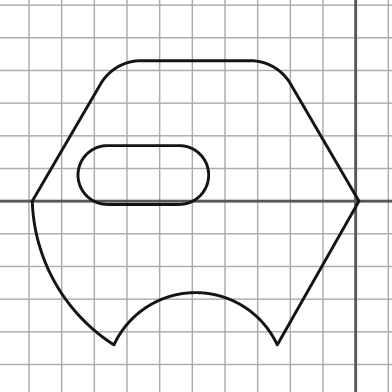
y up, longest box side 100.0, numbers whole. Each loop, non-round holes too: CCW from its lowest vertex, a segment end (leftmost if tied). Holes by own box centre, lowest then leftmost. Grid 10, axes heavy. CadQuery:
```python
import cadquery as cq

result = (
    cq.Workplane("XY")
    .moveTo(-74.0, -44.0)
    .threePointArc((-49.0, -28.0), (-24.0, -44.0))
    .lineTo(1.0, 0.0)
    .lineTo(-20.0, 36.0)
    .threePointArc((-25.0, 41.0), (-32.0, 43.0))
    .lineTo(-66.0, 43.0)
    .threePointArc((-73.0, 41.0), (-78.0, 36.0))
    .lineTo(-99.0, 0.0)
    .threePointArc((-92.0, -25.0), (-74.0, -44.0))
    .close()
    .moveTo(-76.0, -1.0)
    .lineTo(-54.0, -1.0)
    .threePointArc((-45.0, 8.0), (-54.0, 17.0))
    .lineTo(-76.0, 17.0)
    .threePointArc((-85.0, 8.0), (-76.0, -1.0))
    .close()
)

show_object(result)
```